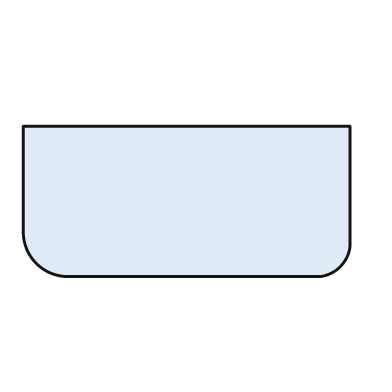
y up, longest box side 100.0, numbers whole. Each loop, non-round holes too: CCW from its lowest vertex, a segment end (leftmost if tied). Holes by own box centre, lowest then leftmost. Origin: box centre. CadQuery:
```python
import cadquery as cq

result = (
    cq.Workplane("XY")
    .moveTo(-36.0, -23.0)
    .lineTo(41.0, -23.0)
    .threePointArc((47.0, -20.0), (50.0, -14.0))
    .lineTo(50.0, 23.0)
    .lineTo(-50.0, 23.0)
    .lineTo(-50.0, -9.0)
    .threePointArc((-46.0, -19.0), (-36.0, -23.0))
    .close()
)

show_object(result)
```